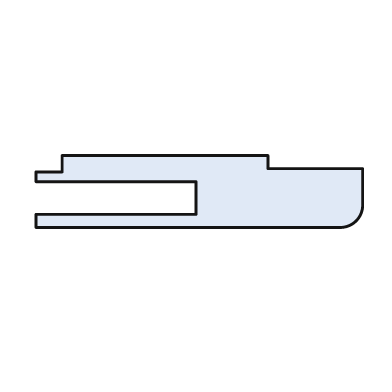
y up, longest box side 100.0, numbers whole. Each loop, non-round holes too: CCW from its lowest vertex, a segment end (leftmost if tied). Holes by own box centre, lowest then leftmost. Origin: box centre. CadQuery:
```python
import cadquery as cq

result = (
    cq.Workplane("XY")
    .moveTo(-50.0, -11.0)
    .lineTo(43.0, -11.0)
    .threePointArc((48.0, -9.0), (50.0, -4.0))
    .lineTo(50.0, 7.0)
    .lineTo(21.0, 7.0)
    .lineTo(21.0, 11.0)
    .lineTo(-42.0, 11.0)
    .lineTo(-42.0, 6.0)
    .lineTo(-50.0, 6.0)
    .lineTo(-50.0, 3.0)
    .lineTo(-1.0, 3.0)
    .lineTo(-1.0, -7.0)
    .lineTo(-50.0, -7.0)
    .close()
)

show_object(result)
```